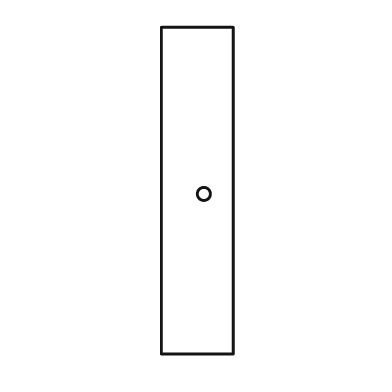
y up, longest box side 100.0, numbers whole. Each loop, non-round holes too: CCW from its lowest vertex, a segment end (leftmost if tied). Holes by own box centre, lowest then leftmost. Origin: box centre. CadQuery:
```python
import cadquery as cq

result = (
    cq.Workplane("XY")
    .moveTo(-11.0, -50.0)
    .lineTo(11.0, -50.0)
    .lineTo(11.0, 50.0)
    .lineTo(-11.0, 50.0)
    .close()
    .moveTo(2.0, -1.0)
    .circle(2.0)
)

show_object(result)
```